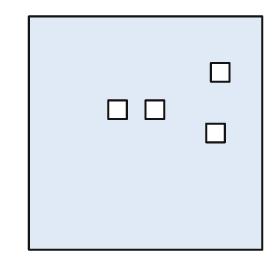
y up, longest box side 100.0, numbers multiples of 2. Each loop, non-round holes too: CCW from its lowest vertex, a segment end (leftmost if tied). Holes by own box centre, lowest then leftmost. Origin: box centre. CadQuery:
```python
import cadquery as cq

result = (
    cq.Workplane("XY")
    .moveTo(-50.0, -50.0)
    .lineTo(50.0, -50.0)
    .lineTo(50.0, 50.0)
    .lineTo(-50.0, 50.0)
    .close()
    .moveTo(26.0, -4.0)
    .lineTo(34.0, -4.0)
    .lineTo(34.0, 4.0)
    .lineTo(26.0, 4.0)
    .close()
    .moveTo(-16.0, 6.0)
    .lineTo(-8.0, 6.0)
    .lineTo(-8.0, 14.0)
    .lineTo(-16.0, 14.0)
    .close()
    .moveTo(0.0, 6.0)
    .lineTo(8.0, 6.0)
    .lineTo(8.0, 14.0)
    .lineTo(0.0, 14.0)
    .close()
    .moveTo(28.0, 22.0)
    .lineTo(36.0, 22.0)
    .lineTo(36.0, 30.0)
    .lineTo(28.0, 30.0)
    .close()
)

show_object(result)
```